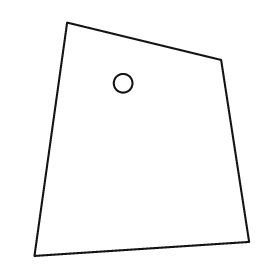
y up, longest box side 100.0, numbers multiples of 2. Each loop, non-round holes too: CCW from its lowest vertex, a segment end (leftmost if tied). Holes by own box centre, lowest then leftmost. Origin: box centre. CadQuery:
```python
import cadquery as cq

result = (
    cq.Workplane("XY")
    .moveTo(-46.0, -50.0)
    .lineTo(46.0, -44.0)
    .lineTo(34.0, 34.0)
    .lineTo(-32.0, 50.0)
    .close()
    .moveTo(-8.0, 24.0)
    .circle(4.0)
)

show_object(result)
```